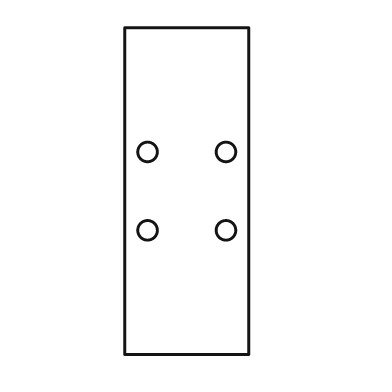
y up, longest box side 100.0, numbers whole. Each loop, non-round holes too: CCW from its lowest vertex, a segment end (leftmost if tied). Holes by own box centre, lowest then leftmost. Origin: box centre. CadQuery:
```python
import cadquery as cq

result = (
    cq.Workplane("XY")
    .moveTo(-19.0, -50.0)
    .lineTo(19.0, -50.0)
    .lineTo(19.0, 50.0)
    .lineTo(-19.0, 50.0)
    .close()
    .moveTo(-12.0, -12.0)
    .circle(3.0)
    .moveTo(12.0, -12.0)
    .circle(3.0)
    .moveTo(-12.0, 12.0)
    .circle(3.0)
    .moveTo(12.0, 12.0)
    .circle(3.0)
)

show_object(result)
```